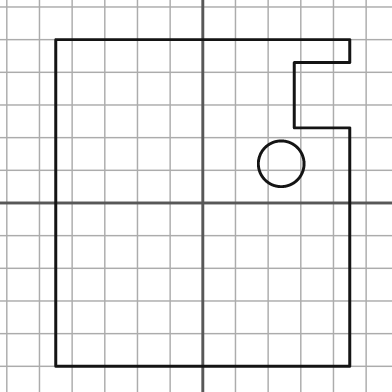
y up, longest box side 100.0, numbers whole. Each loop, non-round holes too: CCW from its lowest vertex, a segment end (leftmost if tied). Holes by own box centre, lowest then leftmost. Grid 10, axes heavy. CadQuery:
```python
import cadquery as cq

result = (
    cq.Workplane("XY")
    .moveTo(-45.0, -50.0)
    .lineTo(45.0, -50.0)
    .lineTo(45.0, 23.0)
    .lineTo(28.0, 23.0)
    .lineTo(28.0, 43.0)
    .lineTo(45.0, 43.0)
    .lineTo(45.0, 50.0)
    .lineTo(-45.0, 50.0)
    .close()
    .moveTo(24.0, 12.0)
    .circle(7.0)
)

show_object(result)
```